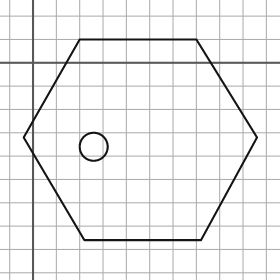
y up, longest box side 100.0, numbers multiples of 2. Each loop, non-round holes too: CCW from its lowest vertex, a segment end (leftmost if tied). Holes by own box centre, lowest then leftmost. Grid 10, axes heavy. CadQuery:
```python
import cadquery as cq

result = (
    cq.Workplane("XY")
    .moveTo(22.0, -76.0)
    .lineTo(72.0, -76.0)
    .lineTo(96.0, -32.0)
    .lineTo(70.0, 10.0)
    .lineTo(20.0, 10.0)
    .lineTo(-4.0, -32.0)
    .close()
    .moveTo(26.0, -36.0)
    .circle(6.0)
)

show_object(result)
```